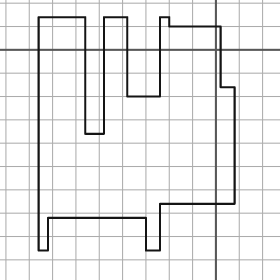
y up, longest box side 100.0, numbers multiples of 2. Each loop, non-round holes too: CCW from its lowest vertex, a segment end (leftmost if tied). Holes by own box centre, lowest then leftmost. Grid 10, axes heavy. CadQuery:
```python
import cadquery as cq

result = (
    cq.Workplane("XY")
    .moveTo(-76.0, -86.0)
    .lineTo(-72.0, -86.0)
    .lineTo(-72.0, -72.0)
    .lineTo(-30.0, -72.0)
    .lineTo(-30.0, -86.0)
    .lineTo(-24.0, -86.0)
    .lineTo(-24.0, -66.0)
    .lineTo(8.0, -66.0)
    .lineTo(8.0, -16.0)
    .lineTo(2.0, -16.0)
    .lineTo(2.0, 10.0)
    .lineTo(-20.0, 10.0)
    .lineTo(-20.0, 14.0)
    .lineTo(-24.0, 14.0)
    .lineTo(-24.0, -20.0)
    .lineTo(-38.0, -20.0)
    .lineTo(-38.0, 14.0)
    .lineTo(-48.0, 14.0)
    .lineTo(-48.0, -36.0)
    .lineTo(-56.0, -36.0)
    .lineTo(-56.0, 14.0)
    .lineTo(-76.0, 14.0)
    .close()
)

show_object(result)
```